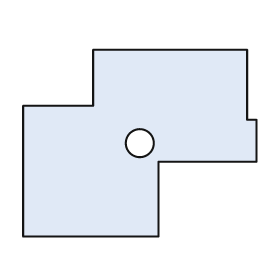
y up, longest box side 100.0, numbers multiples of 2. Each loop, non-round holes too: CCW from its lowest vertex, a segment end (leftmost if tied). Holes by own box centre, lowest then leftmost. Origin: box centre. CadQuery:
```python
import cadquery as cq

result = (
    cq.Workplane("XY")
    .moveTo(-50.0, -40.0)
    .lineTo(8.0, -40.0)
    .lineTo(8.0, -8.0)
    .lineTo(50.0, -8.0)
    .lineTo(50.0, 10.0)
    .lineTo(46.0, 10.0)
    .lineTo(46.0, 40.0)
    .lineTo(-20.0, 40.0)
    .lineTo(-20.0, 16.0)
    .lineTo(-50.0, 16.0)
    .close()
    .moveTo(0.0, 0.0)
    .circle(6.0)
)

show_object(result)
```